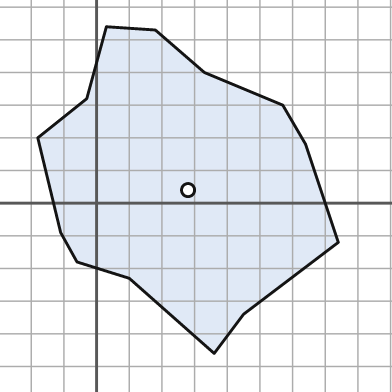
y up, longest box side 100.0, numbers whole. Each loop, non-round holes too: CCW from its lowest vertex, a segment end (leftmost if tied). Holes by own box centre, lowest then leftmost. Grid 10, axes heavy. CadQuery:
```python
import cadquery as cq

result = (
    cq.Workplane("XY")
    .moveTo(36.0, -46.0)
    .lineTo(45.0, -34.0)
    .lineTo(74.0, -12.0)
    .lineTo(64.0, 18.0)
    .lineTo(57.0, 30.0)
    .lineTo(33.0, 40.0)
    .lineTo(18.0, 53.0)
    .lineTo(3.0, 54.0)
    .lineTo(-3.0, 32.0)
    .lineTo(-18.0, 20.0)
    .lineTo(-11.0, -9.0)
    .lineTo(-6.0, -18.0)
    .lineTo(10.0, -23.0)
    .close()
    .moveTo(28.0, 4.0)
    .circle(2.0)
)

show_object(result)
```